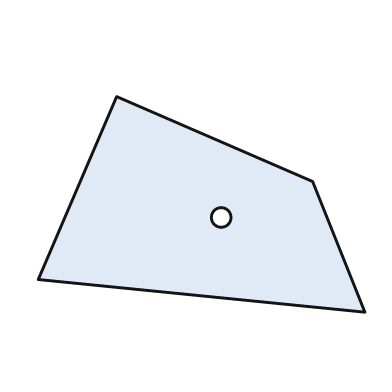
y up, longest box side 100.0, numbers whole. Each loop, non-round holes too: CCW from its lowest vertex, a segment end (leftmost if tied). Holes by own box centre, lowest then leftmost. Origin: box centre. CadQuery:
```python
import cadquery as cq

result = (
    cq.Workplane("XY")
    .moveTo(50.0, -33.0)
    .lineTo(34.0, 7.0)
    .lineTo(-26.0, 33.0)
    .lineTo(-50.0, -23.0)
    .close()
    .moveTo(6.0, -4.0)
    .circle(3.0)
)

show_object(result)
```